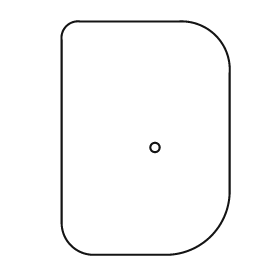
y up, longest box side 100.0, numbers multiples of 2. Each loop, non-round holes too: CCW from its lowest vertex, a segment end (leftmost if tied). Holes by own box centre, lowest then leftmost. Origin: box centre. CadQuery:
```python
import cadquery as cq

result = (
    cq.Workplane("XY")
    .moveTo(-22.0, -50.0)
    .lineTo(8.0, -50.0)
    .threePointArc((28.0, -42.0), (36.0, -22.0))
    .lineTo(36.0, 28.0)
    .threePointArc((30.0, 44.0), (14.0, 50.0))
    .lineTo(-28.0, 50.0)
    .threePointArc((-34.0, 48.0), (-36.0, 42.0))
    .lineTo(-36.0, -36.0)
    .threePointArc((-32.0, -46.0), (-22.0, -50.0))
    .close()
    .moveTo(4.0, -4.0)
    .circle(2.0)
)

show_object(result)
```